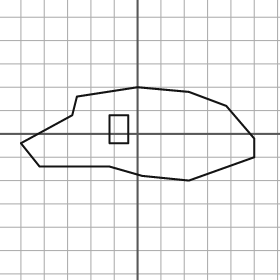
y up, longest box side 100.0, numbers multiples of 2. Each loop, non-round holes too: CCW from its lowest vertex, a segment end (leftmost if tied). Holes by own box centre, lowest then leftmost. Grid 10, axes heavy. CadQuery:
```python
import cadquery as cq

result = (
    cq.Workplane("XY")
    .moveTo(22.0, -20.0)
    .lineTo(50.0, -10.0)
    .lineTo(50.0, -2.0)
    .lineTo(38.0, 12.0)
    .lineTo(22.0, 18.0)
    .lineTo(0.0, 20.0)
    .lineTo(-26.0, 16.0)
    .lineTo(-28.0, 8.0)
    .lineTo(-50.0, -4.0)
    .lineTo(-42.0, -14.0)
    .lineTo(-12.0, -14.0)
    .lineTo(2.0, -18.0)
    .close()
    .moveTo(-12.0, -4.0)
    .lineTo(-4.0, -4.0)
    .lineTo(-4.0, 8.0)
    .lineTo(-12.0, 8.0)
    .close()
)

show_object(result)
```